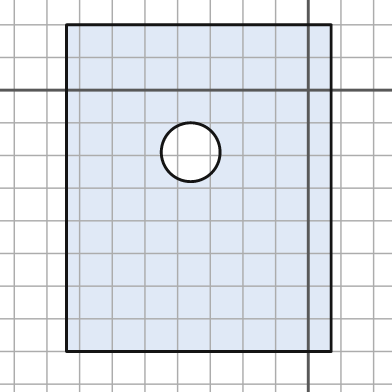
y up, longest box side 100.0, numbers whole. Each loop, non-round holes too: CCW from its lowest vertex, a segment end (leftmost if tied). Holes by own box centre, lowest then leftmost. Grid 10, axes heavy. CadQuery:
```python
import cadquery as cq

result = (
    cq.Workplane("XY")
    .moveTo(-74.0, -80.0)
    .lineTo(7.0, -80.0)
    .lineTo(7.0, 20.0)
    .lineTo(-74.0, 20.0)
    .close()
    .moveTo(-36.0, -19.0)
    .circle(9.0)
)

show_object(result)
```